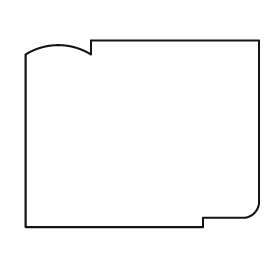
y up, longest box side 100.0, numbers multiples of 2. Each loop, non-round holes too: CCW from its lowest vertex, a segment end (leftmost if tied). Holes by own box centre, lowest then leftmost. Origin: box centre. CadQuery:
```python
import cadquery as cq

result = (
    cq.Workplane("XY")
    .moveTo(-50.0, -40.0)
    .lineTo(26.0, -40.0)
    .lineTo(26.0, -36.0)
    .lineTo(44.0, -36.0)
    .threePointArc((48.0, -34.0), (50.0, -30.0))
    .lineTo(50.0, 40.0)
    .lineTo(-22.0, 40.0)
    .lineTo(-22.0, 34.0)
    .threePointArc((-36.0, 38.0), (-50.0, 34.0))
    .close()
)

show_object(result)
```